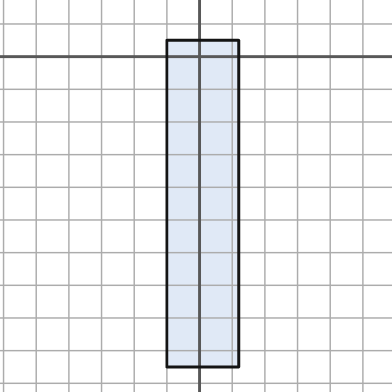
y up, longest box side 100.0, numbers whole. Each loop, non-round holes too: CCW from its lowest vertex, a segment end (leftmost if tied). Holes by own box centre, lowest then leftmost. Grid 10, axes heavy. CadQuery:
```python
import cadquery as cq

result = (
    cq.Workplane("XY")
    .moveTo(-10.0, -95.0)
    .lineTo(12.0, -95.0)
    .lineTo(12.0, 5.0)
    .lineTo(-10.0, 5.0)
    .close()
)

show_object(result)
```